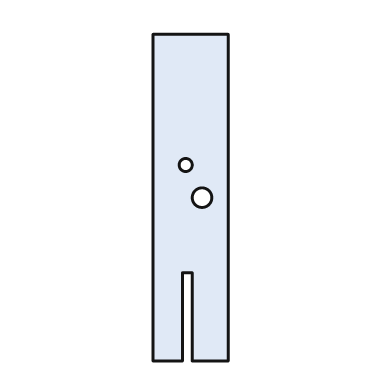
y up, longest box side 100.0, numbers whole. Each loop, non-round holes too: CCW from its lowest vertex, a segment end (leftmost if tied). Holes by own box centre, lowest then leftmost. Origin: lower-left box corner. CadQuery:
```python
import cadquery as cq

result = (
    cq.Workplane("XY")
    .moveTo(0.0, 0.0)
    .lineTo(9.0, 0.0)
    .lineTo(9.0, 27.0)
    .lineTo(12.0, 27.0)
    .lineTo(12.0, 0.0)
    .lineTo(23.0, 0.0)
    .lineTo(23.0, 100.0)
    .lineTo(0.0, 100.0)
    .close()
    .moveTo(15.0, 50.0)
    .circle(3.0)
    .moveTo(10.0, 60.0)
    .circle(2.0)
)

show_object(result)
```